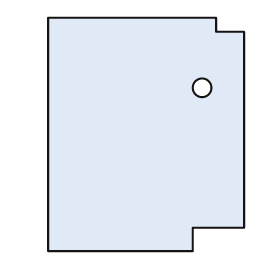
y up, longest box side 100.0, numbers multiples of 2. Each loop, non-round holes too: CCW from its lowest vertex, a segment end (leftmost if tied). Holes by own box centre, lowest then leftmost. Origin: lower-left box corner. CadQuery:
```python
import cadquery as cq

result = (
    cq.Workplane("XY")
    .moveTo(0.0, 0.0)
    .lineTo(62.0, 0.0)
    .lineTo(62.0, 10.0)
    .lineTo(84.0, 10.0)
    .lineTo(84.0, 94.0)
    .lineTo(72.0, 94.0)
    .lineTo(72.0, 100.0)
    .lineTo(0.0, 100.0)
    .close()
    .moveTo(66.0, 70.0)
    .circle(4.0)
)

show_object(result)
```